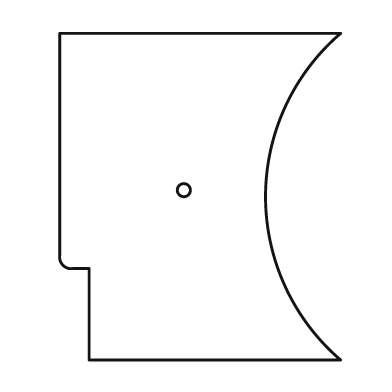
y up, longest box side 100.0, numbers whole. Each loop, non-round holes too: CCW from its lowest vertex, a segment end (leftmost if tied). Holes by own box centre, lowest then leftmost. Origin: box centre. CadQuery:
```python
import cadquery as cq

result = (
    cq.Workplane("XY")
    .moveTo(-34.0, -50.0)
    .lineTo(43.0, -50.0)
    .threePointArc((20.0, 0.0), (43.0, 50.0))
    .lineTo(-43.0, 50.0)
    .lineTo(-43.0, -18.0)
    .threePointArc((-42.0, -21.0), (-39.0, -22.0))
    .lineTo(-34.0, -22.0)
    .close()
    .moveTo(-5.0, 2.0)
    .circle(2.0)
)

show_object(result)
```